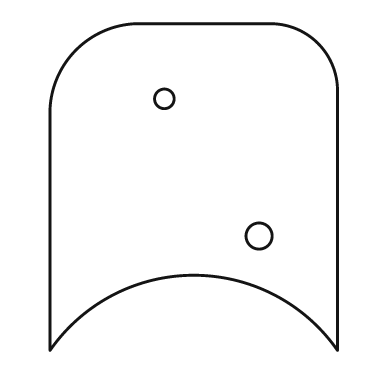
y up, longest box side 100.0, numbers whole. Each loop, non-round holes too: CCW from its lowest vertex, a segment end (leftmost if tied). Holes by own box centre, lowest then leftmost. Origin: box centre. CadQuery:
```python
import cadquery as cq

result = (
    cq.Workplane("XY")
    .moveTo(-44.0, -50.0)
    .threePointArc((0.0, -27.0), (44.0, -50.0))
    .lineTo(44.0, 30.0)
    .threePointArc((38.0, 44.0), (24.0, 50.0))
    .lineTo(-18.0, 50.0)
    .threePointArc((-36.0, 42.0), (-44.0, 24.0))
    .close()
    .moveTo(20.0, -15.0)
    .circle(4.0)
    .moveTo(-9.0, 27.0)
    .circle(3.0)
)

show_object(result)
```